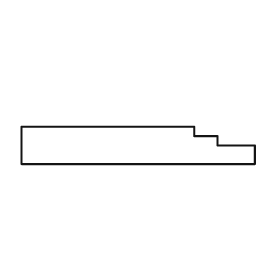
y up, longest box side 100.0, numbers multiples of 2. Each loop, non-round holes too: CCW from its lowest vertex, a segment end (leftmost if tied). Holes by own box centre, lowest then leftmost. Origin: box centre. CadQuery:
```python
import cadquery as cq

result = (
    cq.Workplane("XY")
    .moveTo(-50.0, -8.0)
    .lineTo(50.0, -8.0)
    .lineTo(50.0, 0.0)
    .lineTo(34.0, 0.0)
    .lineTo(34.0, 4.0)
    .lineTo(24.0, 4.0)
    .lineTo(24.0, 8.0)
    .lineTo(-50.0, 8.0)
    .close()
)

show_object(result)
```